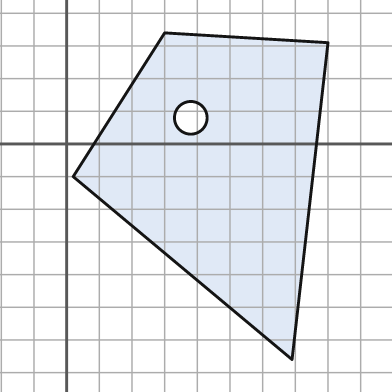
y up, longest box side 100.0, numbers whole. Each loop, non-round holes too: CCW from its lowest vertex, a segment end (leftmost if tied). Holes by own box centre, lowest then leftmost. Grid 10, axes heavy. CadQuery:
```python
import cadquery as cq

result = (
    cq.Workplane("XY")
    .moveTo(69.0, -66.0)
    .lineTo(80.0, 31.0)
    .lineTo(30.0, 34.0)
    .lineTo(2.0, -10.0)
    .close()
    .moveTo(38.0, 8.0)
    .circle(5.0)
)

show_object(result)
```